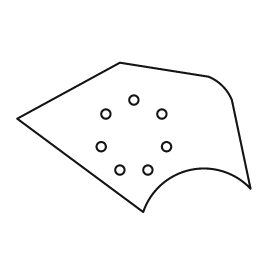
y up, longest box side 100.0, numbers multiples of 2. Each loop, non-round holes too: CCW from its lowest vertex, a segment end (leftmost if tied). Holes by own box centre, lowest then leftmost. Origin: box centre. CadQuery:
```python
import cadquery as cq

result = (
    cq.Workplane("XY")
    .moveTo(4.0, -32.0)
    .threePointArc((24.0, -14.0), (50.0, -22.0))
    .lineTo(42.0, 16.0)
    .threePointArc((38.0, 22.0), (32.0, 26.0))
    .lineTo(-6.0, 32.0)
    .lineTo(-50.0, 8.0)
    .close()
    .moveTo(-6.0, -14.0)
    .circle(2.0)
    .moveTo(6.0, -14.0)
    .circle(2.0)
    .moveTo(-14.0, -4.0)
    .circle(2.0)
    .moveTo(14.0, -4.0)
    .circle(2.0)
    .moveTo(-12.0, 10.0)
    .circle(2.0)
    .moveTo(12.0, 10.0)
    .circle(2.0)
    .moveTo(0.0, 16.0)
    .circle(2.0)
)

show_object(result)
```